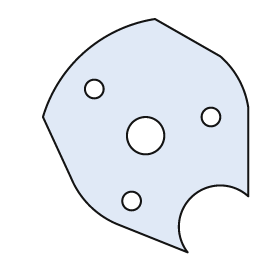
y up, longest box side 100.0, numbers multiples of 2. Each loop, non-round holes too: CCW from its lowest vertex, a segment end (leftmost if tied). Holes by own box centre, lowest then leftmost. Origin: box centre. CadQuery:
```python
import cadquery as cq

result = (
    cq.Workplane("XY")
    .moveTo(18.0, -50.0)
    .threePointArc((20.0, -26.0), (44.0, -26.0))
    .lineTo(44.0, 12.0)
    .threePointArc((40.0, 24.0), (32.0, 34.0))
    .lineTo(4.0, 50.0)
    .threePointArc((-26.0, 36.0), (-44.0, 8.0))
    .lineTo(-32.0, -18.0)
    .threePointArc((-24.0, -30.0), (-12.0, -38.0))
    .close()
    .moveTo(-6.0, -28.0)
    .circle(4.0)
    .moveTo(0.0, 0.0)
    .circle(8.0)
    .moveTo(28.0, 8.0)
    .circle(4.0)
    .moveTo(-22.0, 20.0)
    .circle(4.0)
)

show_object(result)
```